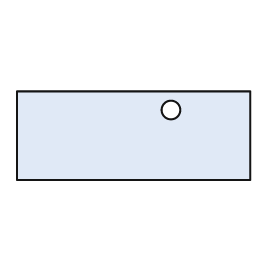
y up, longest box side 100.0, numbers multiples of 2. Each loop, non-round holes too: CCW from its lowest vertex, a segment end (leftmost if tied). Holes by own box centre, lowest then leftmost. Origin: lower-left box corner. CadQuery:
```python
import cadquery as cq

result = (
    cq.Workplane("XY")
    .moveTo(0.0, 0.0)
    .lineTo(100.0, 0.0)
    .lineTo(100.0, 38.0)
    .lineTo(0.0, 38.0)
    .close()
    .moveTo(66.0, 30.0)
    .circle(4.0)
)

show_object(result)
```